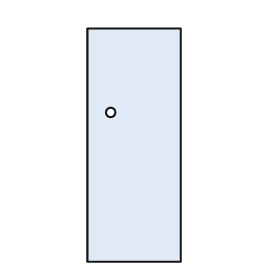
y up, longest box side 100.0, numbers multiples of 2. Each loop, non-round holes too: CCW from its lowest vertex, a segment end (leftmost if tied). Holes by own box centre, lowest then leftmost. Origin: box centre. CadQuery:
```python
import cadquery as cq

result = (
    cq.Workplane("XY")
    .moveTo(-20.0, -50.0)
    .lineTo(20.0, -50.0)
    .lineTo(20.0, 50.0)
    .lineTo(-20.0, 50.0)
    .close()
    .moveTo(-10.0, 14.0)
    .circle(2.0)
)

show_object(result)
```